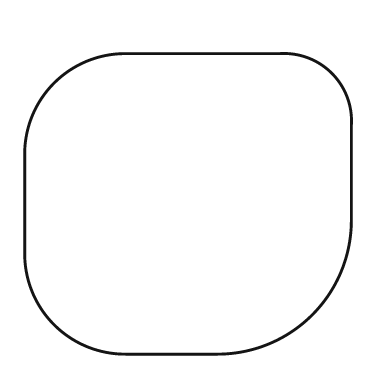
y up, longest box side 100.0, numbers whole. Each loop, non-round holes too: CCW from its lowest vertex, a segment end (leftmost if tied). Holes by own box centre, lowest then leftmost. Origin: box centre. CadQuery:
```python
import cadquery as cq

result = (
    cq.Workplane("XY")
    .moveTo(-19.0, -46.0)
    .lineTo(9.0, -46.0)
    .threePointArc((38.0, -34.0), (50.0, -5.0))
    .lineTo(50.0, 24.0)
    .threePointArc((44.0, 40.0), (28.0, 46.0))
    .lineTo(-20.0, 46.0)
    .threePointArc((-41.0, 37.0), (-50.0, 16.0))
    .lineTo(-50.0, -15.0)
    .threePointArc((-41.0, -37.0), (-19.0, -46.0))
    .close()
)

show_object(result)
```